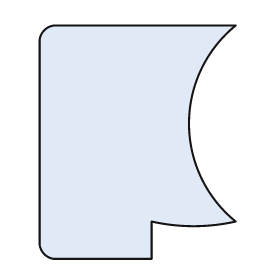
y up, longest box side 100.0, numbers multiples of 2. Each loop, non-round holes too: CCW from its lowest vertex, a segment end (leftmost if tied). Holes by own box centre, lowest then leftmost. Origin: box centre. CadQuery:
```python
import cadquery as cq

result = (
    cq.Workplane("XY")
    .moveTo(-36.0, -50.0)
    .lineTo(6.0, -50.0)
    .lineTo(6.0, -34.0)
    .threePointArc((24.0, -36.0), (42.0, -34.0))
    .threePointArc((22.0, 8.0), (42.0, 50.0))
    .lineTo(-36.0, 50.0)
    .threePointArc((-40.0, 48.0), (-42.0, 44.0))
    .lineTo(-42.0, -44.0)
    .threePointArc((-40.0, -48.0), (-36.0, -50.0))
    .close()
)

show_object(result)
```